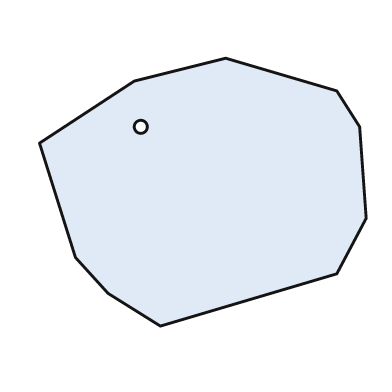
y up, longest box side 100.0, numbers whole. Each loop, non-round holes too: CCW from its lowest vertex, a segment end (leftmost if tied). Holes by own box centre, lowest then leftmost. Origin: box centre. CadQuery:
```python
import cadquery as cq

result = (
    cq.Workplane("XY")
    .moveTo(-13.0, -41.0)
    .lineTo(41.0, -25.0)
    .lineTo(50.0, -8.0)
    .lineTo(48.0, 20.0)
    .lineTo(41.0, 31.0)
    .lineTo(7.0, 41.0)
    .lineTo(-21.0, 34.0)
    .lineTo(-50.0, 15.0)
    .lineTo(-39.0, -20.0)
    .lineTo(-29.0, -31.0)
    .close()
    .moveTo(-19.0, 20.0)
    .circle(2.0)
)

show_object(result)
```